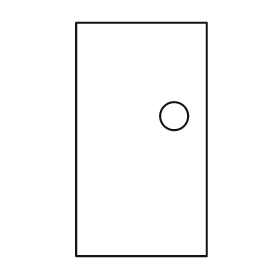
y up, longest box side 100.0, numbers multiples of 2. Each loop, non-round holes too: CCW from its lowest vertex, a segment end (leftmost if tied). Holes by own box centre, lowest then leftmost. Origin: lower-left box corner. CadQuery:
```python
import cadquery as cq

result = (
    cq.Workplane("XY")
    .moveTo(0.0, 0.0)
    .lineTo(56.0, 0.0)
    .lineTo(56.0, 100.0)
    .lineTo(0.0, 100.0)
    .close()
    .moveTo(42.0, 60.0)
    .circle(6.0)
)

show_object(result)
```